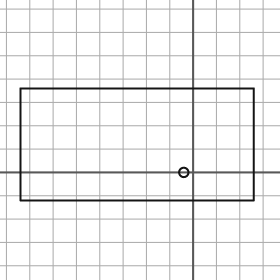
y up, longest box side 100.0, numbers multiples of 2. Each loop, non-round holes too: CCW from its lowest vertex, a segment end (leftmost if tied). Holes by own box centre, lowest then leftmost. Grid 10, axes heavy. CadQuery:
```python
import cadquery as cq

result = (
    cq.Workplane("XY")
    .moveTo(-74.0, -12.0)
    .lineTo(26.0, -12.0)
    .lineTo(26.0, 36.0)
    .lineTo(-74.0, 36.0)
    .close()
    .moveTo(-4.0, 0.0)
    .circle(2.0)
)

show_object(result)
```